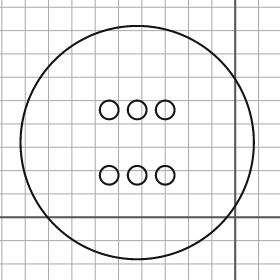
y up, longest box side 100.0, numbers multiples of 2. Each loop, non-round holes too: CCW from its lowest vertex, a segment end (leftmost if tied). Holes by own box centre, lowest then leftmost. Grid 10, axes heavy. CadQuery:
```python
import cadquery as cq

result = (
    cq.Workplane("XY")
    .moveTo(-42.0, 32.0)
    .circle(50.0)
    .moveTo(-54.0, 18.0)
    .circle(4.0)
    .moveTo(-42.0, 18.0)
    .circle(4.0)
    .moveTo(-30.0, 18.0)
    .circle(4.0)
    .moveTo(-54.0, 46.0)
    .circle(4.0)
    .moveTo(-42.0, 46.0)
    .circle(4.0)
    .moveTo(-30.0, 46.0)
    .circle(4.0)
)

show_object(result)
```